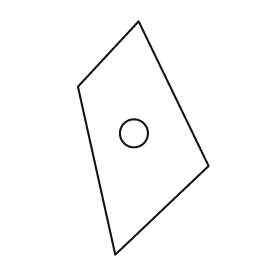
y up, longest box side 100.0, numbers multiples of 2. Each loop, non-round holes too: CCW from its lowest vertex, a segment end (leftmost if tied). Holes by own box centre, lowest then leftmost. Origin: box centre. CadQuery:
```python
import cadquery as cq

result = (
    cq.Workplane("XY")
    .moveTo(-12.0, -50.0)
    .lineTo(28.0, -12.0)
    .lineTo(-2.0, 50.0)
    .lineTo(-28.0, 22.0)
    .close()
    .moveTo(-4.0, 2.0)
    .circle(6.0)
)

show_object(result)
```